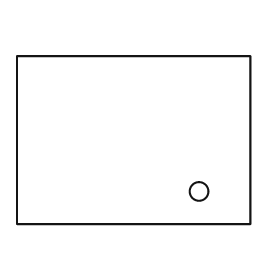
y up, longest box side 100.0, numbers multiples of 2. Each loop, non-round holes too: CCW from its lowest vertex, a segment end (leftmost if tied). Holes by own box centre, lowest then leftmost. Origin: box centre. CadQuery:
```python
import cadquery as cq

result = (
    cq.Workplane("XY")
    .moveTo(-50.0, -36.0)
    .lineTo(50.0, -36.0)
    .lineTo(50.0, 36.0)
    .lineTo(-50.0, 36.0)
    .close()
    .moveTo(28.0, -22.0)
    .circle(4.0)
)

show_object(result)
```